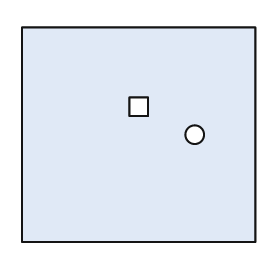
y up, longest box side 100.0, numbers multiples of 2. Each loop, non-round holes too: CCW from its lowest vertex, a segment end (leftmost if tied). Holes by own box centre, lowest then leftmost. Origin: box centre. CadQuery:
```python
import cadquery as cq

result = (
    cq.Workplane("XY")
    .moveTo(-50.0, -46.0)
    .lineTo(50.0, -46.0)
    .lineTo(50.0, 46.0)
    .lineTo(-50.0, 46.0)
    .close()
    .moveTo(24.0, 0.0)
    .circle(4.0)
    .moveTo(-4.0, 8.0)
    .lineTo(4.0, 8.0)
    .lineTo(4.0, 16.0)
    .lineTo(-4.0, 16.0)
    .close()
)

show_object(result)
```